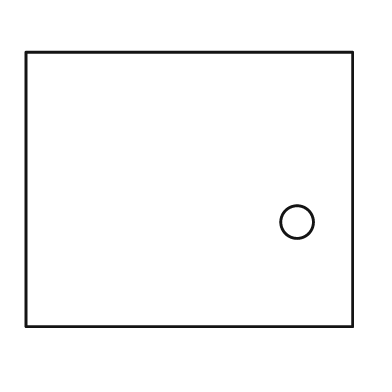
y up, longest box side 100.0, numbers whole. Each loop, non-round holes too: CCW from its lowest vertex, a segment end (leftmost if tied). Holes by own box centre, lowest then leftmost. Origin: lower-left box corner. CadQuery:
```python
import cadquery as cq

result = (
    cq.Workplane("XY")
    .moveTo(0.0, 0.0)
    .lineTo(100.0, 0.0)
    .lineTo(100.0, 84.0)
    .lineTo(0.0, 84.0)
    .close()
    .moveTo(83.0, 32.0)
    .circle(5.0)
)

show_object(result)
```